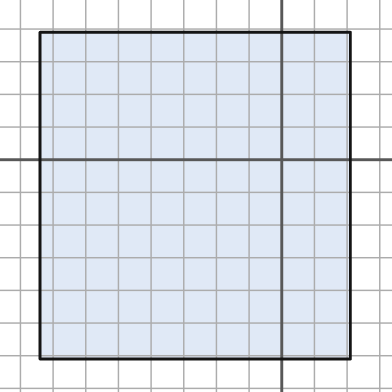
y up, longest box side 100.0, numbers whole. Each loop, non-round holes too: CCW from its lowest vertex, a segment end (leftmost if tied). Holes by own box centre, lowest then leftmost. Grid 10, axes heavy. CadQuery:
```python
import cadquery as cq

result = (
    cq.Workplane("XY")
    .moveTo(-74.0, -61.0)
    .lineTo(21.0, -61.0)
    .lineTo(21.0, 39.0)
    .lineTo(-74.0, 39.0)
    .close()
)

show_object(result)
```